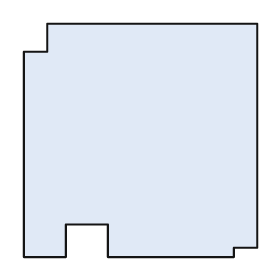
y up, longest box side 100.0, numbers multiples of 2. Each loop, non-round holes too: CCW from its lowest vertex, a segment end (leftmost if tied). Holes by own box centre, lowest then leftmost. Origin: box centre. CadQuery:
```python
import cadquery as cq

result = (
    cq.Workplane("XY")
    .moveTo(-50.0, -50.0)
    .lineTo(-32.0, -50.0)
    .lineTo(-32.0, -36.0)
    .lineTo(-14.0, -36.0)
    .lineTo(-14.0, -50.0)
    .lineTo(40.0, -50.0)
    .lineTo(40.0, -46.0)
    .lineTo(50.0, -46.0)
    .lineTo(50.0, 50.0)
    .lineTo(-40.0, 50.0)
    .lineTo(-40.0, 38.0)
    .lineTo(-50.0, 38.0)
    .close()
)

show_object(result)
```